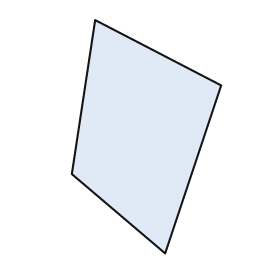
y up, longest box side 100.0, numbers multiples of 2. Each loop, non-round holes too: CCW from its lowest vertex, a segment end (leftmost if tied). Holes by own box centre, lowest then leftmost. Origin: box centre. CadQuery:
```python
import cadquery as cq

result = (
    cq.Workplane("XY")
    .moveTo(8.0, -50.0)
    .lineTo(32.0, 22.0)
    .lineTo(-22.0, 50.0)
    .lineTo(-32.0, -16.0)
    .close()
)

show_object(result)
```